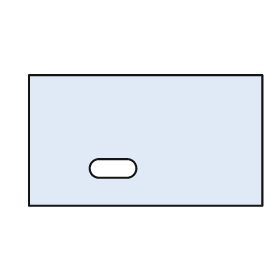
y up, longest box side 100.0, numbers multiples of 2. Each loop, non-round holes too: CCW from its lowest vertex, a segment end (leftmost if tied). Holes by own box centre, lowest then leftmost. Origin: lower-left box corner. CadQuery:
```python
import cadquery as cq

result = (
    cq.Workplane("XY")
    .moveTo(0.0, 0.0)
    .lineTo(100.0, 0.0)
    .lineTo(100.0, 56.0)
    .lineTo(0.0, 56.0)
    .close()
    .moveTo(30.0, 12.0)
    .lineTo(42.0, 12.0)
    .threePointArc((46.0, 16.0), (42.0, 20.0))
    .lineTo(30.0, 20.0)
    .threePointArc((26.0, 16.0), (30.0, 12.0))
    .close()
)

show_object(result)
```